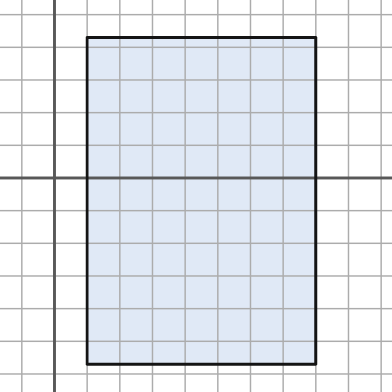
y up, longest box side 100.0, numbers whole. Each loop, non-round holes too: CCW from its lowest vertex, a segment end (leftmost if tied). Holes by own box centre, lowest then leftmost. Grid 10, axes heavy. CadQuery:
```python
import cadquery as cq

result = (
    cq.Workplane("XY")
    .moveTo(10.0, -57.0)
    .lineTo(80.0, -57.0)
    .lineTo(80.0, 43.0)
    .lineTo(10.0, 43.0)
    .close()
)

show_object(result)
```